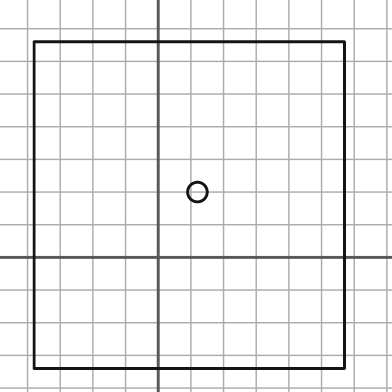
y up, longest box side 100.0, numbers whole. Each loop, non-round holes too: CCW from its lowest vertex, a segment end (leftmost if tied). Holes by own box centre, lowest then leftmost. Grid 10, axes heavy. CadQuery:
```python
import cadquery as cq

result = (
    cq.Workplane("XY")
    .moveTo(-38.0, -34.0)
    .lineTo(57.0, -34.0)
    .lineTo(57.0, 66.0)
    .lineTo(-38.0, 66.0)
    .close()
    .moveTo(12.0, 20.0)
    .circle(3.0)
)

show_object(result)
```